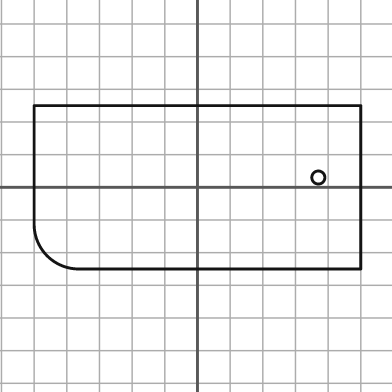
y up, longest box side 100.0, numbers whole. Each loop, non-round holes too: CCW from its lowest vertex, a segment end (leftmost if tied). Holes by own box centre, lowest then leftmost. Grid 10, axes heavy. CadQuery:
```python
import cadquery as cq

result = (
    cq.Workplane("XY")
    .moveTo(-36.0, -25.0)
    .lineTo(50.0, -25.0)
    .lineTo(50.0, 25.0)
    .lineTo(-50.0, 25.0)
    .lineTo(-50.0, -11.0)
    .threePointArc((-46.0, -21.0), (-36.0, -25.0))
    .close()
    .moveTo(37.0, 3.0)
    .circle(2.0)
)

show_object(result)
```